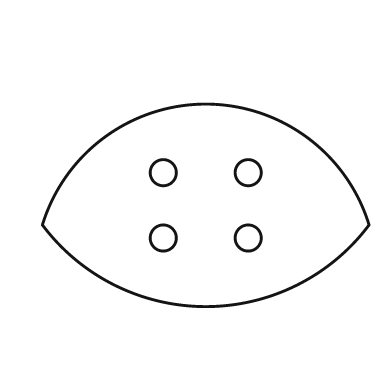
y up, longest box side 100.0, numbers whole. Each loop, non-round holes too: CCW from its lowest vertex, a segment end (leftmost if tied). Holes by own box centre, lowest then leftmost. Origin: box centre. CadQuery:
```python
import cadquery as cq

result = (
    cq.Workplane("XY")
    .moveTo(-50.0, -6.0)
    .threePointArc((0.0, -31.0), (50.0, -6.0))
    .threePointArc((0.0, 31.0), (-50.0, -6.0))
    .close()
    .moveTo(-13.0, -10.0)
    .circle(4.0)
    .moveTo(13.0, -10.0)
    .circle(4.0)
    .moveTo(-13.0, 10.0)
    .circle(4.0)
    .moveTo(13.0, 10.0)
    .circle(4.0)
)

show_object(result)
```